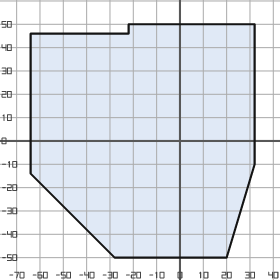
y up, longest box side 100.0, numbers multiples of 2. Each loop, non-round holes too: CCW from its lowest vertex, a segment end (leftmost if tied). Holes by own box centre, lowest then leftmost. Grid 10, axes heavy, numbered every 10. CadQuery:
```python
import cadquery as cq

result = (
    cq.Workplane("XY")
    .moveTo(-28.0, -50.0)
    .lineTo(20.0, -50.0)
    .lineTo(32.0, -10.0)
    .lineTo(32.0, 50.0)
    .lineTo(-22.0, 50.0)
    .lineTo(-22.0, 46.0)
    .lineTo(-64.0, 46.0)
    .lineTo(-64.0, -14.0)
    .close()
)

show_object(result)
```